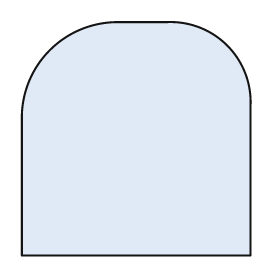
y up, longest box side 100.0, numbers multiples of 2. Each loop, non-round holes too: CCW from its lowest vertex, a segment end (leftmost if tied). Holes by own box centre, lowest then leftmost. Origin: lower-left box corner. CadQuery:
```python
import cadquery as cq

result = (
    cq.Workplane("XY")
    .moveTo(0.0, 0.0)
    .lineTo(98.0, 0.0)
    .lineTo(98.0, 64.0)
    .threePointArc((88.0, 90.0), (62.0, 100.0))
    .lineTo(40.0, 100.0)
    .threePointArc((12.0, 88.0), (0.0, 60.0))
    .close()
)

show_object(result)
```